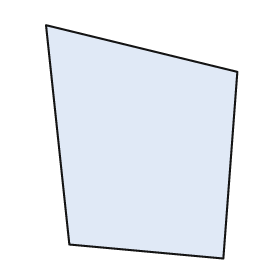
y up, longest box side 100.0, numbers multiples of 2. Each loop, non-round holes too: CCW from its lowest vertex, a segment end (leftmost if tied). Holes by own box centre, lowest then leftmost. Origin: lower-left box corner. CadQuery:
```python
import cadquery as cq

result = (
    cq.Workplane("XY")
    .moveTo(76.0, 0.0)
    .lineTo(82.0, 80.0)
    .lineTo(0.0, 100.0)
    .lineTo(10.0, 6.0)
    .close()
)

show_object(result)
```